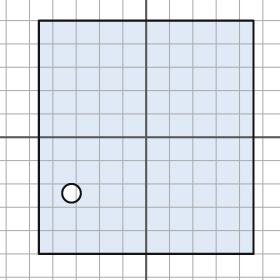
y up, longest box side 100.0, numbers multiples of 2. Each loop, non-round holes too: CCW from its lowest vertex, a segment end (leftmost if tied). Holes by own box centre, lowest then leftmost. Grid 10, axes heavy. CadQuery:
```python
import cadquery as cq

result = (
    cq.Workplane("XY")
    .moveTo(-46.0, -50.0)
    .lineTo(46.0, -50.0)
    .lineTo(46.0, 50.0)
    .lineTo(-46.0, 50.0)
    .close()
    .moveTo(-32.0, -24.0)
    .circle(4.0)
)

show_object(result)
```